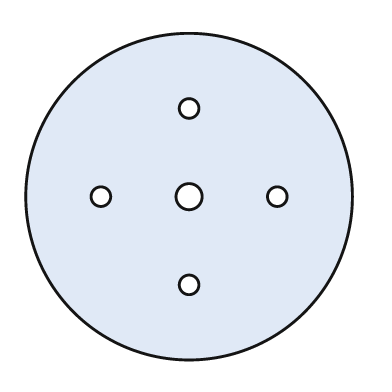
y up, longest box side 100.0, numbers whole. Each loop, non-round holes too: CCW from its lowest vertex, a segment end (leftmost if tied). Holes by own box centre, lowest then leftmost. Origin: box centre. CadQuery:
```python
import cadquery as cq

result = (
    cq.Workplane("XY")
    .moveTo(0.0, 0.0)
    .circle(50.0)
    .moveTo(0.0, -27.0)
    .circle(3.0)
    .moveTo(-27.0, 0.0)
    .circle(3.0)
    .moveTo(0.0, 0.0)
    .circle(4.0)
    .moveTo(27.0, 0.0)
    .circle(3.0)
    .moveTo(0.0, 27.0)
    .circle(3.0)
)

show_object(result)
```